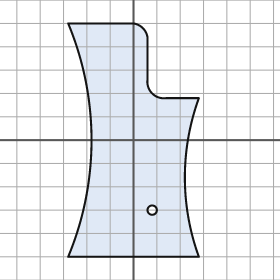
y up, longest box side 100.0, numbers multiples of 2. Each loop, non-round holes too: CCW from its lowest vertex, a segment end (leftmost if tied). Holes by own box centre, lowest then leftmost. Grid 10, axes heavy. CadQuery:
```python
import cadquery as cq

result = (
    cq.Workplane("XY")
    .moveTo(-28.0, -50.0)
    .lineTo(28.0, -50.0)
    .threePointArc((22.0, -16.0), (28.0, 18.0))
    .lineTo(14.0, 18.0)
    .threePointArc((8.0, 20.0), (6.0, 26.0))
    .lineTo(6.0, 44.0)
    .threePointArc((4.0, 48.0), (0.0, 50.0))
    .lineTo(-28.0, 50.0)
    .threePointArc((-18.0, 0.0), (-28.0, -50.0))
    .close()
    .moveTo(8.0, -30.0)
    .circle(2.0)
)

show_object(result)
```